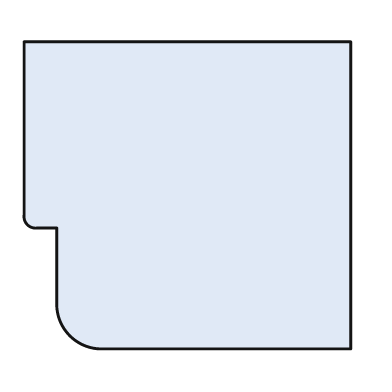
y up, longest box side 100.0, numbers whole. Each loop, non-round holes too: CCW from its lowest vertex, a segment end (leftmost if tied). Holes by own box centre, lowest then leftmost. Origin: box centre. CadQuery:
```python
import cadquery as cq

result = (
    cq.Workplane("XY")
    .moveTo(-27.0, -47.0)
    .lineTo(50.0, -47.0)
    .lineTo(50.0, 47.0)
    .lineTo(-50.0, 47.0)
    .lineTo(-50.0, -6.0)
    .threePointArc((-49.0, -9.0), (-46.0, -10.0))
    .lineTo(-40.0, -10.0)
    .lineTo(-40.0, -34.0)
    .threePointArc((-36.0, -43.0), (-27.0, -47.0))
    .close()
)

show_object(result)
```